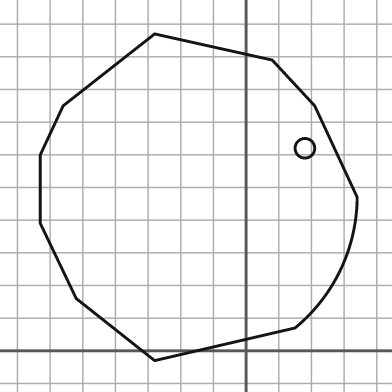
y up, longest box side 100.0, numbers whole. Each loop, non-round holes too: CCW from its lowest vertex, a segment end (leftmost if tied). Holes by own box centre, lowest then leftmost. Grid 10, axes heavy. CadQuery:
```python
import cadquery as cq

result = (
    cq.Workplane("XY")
    .moveTo(-28.0, -3.0)
    .lineTo(15.0, 7.0)
    .threePointArc((29.0, 25.0), (34.0, 47.0))
    .lineTo(21.0, 75.0)
    .lineTo(8.0, 89.0)
    .lineTo(-28.0, 97.0)
    .lineTo(-56.0, 75.0)
    .lineTo(-63.0, 60.0)
    .lineTo(-63.0, 39.0)
    .lineTo(-52.0, 16.0)
    .close()
    .moveTo(18.0, 62.0)
    .circle(3.0)
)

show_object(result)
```